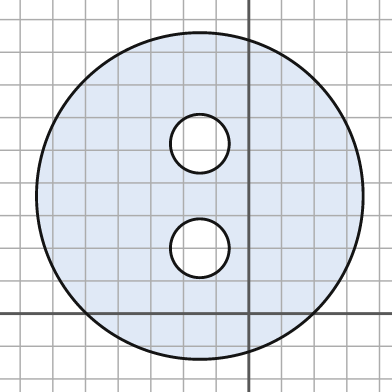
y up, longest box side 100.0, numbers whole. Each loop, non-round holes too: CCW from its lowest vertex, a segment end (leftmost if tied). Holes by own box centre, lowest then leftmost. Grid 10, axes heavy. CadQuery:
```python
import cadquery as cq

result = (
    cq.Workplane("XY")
    .moveTo(-15.0, 36.0)
    .circle(50.0)
    .moveTo(-15.0, 20.0)
    .circle(9.0)
    .moveTo(-15.0, 52.0)
    .circle(9.0)
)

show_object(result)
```